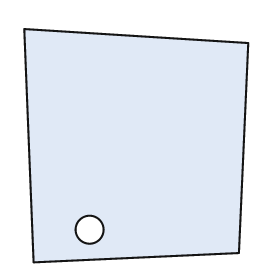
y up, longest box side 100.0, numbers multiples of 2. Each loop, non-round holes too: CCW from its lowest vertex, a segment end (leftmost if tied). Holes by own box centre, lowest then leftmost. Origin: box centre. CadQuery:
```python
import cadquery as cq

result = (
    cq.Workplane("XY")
    .moveTo(-44.0, -50.0)
    .lineTo(44.0, -46.0)
    .lineTo(48.0, 44.0)
    .lineTo(-48.0, 50.0)
    .close()
    .moveTo(-20.0, -36.0)
    .circle(6.0)
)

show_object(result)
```